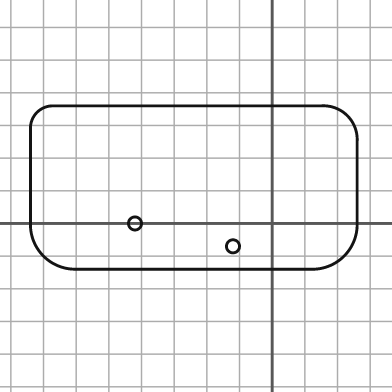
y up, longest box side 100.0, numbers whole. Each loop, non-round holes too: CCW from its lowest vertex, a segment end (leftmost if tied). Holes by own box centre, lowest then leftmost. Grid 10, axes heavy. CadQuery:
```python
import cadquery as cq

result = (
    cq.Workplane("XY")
    .moveTo(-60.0, -14.0)
    .lineTo(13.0, -14.0)
    .threePointArc((22.0, -10.0), (26.0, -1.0))
    .lineTo(26.0, 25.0)
    .threePointArc((23.0, 33.0), (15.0, 36.0))
    .lineTo(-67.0, 36.0)
    .threePointArc((-72.0, 34.0), (-74.0, 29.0))
    .lineTo(-74.0, 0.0)
    .threePointArc((-70.0, -10.0), (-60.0, -14.0))
    .close()
    .moveTo(-12.0, -7.0)
    .circle(2.0)
    .moveTo(-42.0, 0.0)
    .circle(2.0)
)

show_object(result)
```